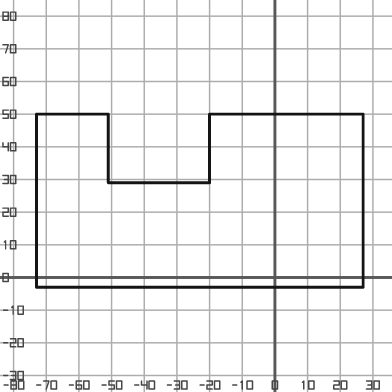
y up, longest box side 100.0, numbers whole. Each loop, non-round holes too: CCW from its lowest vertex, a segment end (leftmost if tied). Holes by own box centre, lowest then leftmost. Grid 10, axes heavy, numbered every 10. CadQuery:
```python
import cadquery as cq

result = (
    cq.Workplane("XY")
    .moveTo(-73.0, -3.0)
    .lineTo(27.0, -3.0)
    .lineTo(27.0, 50.0)
    .lineTo(-20.0, 50.0)
    .lineTo(-20.0, 29.0)
    .lineTo(-51.0, 29.0)
    .lineTo(-51.0, 50.0)
    .lineTo(-73.0, 50.0)
    .close()
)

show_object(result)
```